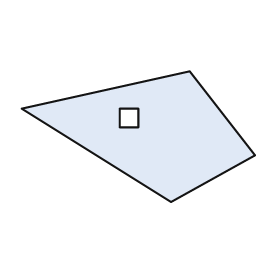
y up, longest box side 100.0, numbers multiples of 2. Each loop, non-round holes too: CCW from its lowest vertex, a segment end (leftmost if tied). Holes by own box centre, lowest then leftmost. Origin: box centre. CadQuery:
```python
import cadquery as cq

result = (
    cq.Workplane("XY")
    .moveTo(14.0, -28.0)
    .lineTo(50.0, -8.0)
    .lineTo(22.0, 28.0)
    .lineTo(-50.0, 12.0)
    .close()
    .moveTo(-8.0, 4.0)
    .lineTo(0.0, 4.0)
    .lineTo(0.0, 12.0)
    .lineTo(-8.0, 12.0)
    .close()
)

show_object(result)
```